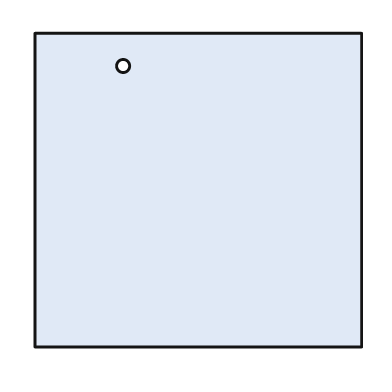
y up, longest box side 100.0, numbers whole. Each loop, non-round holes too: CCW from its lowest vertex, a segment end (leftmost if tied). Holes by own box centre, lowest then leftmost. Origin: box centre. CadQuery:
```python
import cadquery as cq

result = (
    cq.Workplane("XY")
    .moveTo(-50.0, -48.0)
    .lineTo(50.0, -48.0)
    .lineTo(50.0, 48.0)
    .lineTo(-50.0, 48.0)
    .close()
    .moveTo(-23.0, 38.0)
    .circle(2.0)
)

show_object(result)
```